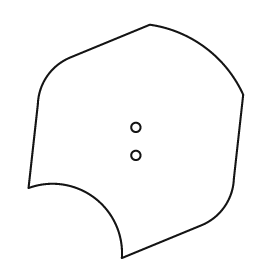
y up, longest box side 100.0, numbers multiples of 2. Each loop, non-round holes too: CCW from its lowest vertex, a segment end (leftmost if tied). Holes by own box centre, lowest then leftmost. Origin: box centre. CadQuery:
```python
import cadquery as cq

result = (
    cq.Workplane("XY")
    .moveTo(-6.0, -50.0)
    .lineTo(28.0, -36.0)
    .threePointArc((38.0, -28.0), (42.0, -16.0))
    .lineTo(46.0, 20.0)
    .threePointArc((30.0, 40.0), (6.0, 50.0))
    .lineTo(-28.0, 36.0)
    .threePointArc((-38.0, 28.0), (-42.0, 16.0))
    .lineTo(-46.0, -20.0)
    .threePointArc((-18.0, -24.0), (-6.0, -50.0))
    .close()
    .moveTo(0.0, -6.0)
    .circle(2.0)
    .moveTo(0.0, 6.0)
    .circle(2.0)
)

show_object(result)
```